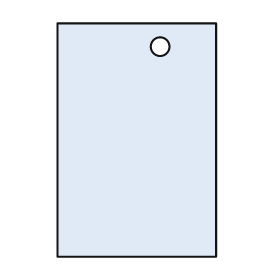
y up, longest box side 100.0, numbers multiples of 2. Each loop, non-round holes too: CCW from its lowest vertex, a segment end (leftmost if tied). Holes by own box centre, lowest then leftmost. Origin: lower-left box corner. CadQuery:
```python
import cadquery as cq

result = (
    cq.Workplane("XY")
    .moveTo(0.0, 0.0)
    .lineTo(68.0, 0.0)
    .lineTo(68.0, 100.0)
    .lineTo(0.0, 100.0)
    .close()
    .moveTo(44.0, 90.0)
    .circle(4.0)
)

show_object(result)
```